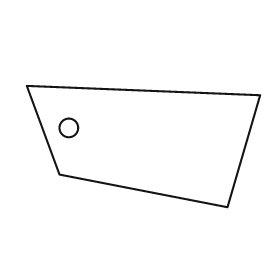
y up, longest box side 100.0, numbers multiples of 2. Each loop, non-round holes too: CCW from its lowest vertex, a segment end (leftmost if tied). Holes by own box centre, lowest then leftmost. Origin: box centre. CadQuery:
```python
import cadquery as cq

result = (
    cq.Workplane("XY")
    .moveTo(36.0, -26.0)
    .lineTo(50.0, 22.0)
    .lineTo(-50.0, 26.0)
    .lineTo(-36.0, -12.0)
    .close()
    .moveTo(-32.0, 8.0)
    .circle(4.0)
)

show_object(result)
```